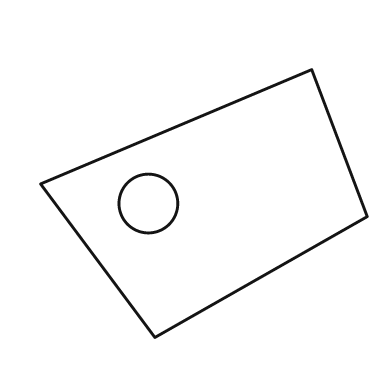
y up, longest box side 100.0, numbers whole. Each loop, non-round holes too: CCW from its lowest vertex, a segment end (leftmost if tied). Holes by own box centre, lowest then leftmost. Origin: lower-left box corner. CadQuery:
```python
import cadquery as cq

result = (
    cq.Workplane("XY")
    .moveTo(35.0, 0.0)
    .lineTo(100.0, 37.0)
    .lineTo(83.0, 82.0)
    .lineTo(0.0, 47.0)
    .close()
    .moveTo(33.0, 41.0)
    .circle(9.0)
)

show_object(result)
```